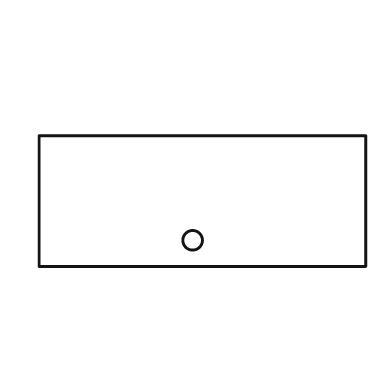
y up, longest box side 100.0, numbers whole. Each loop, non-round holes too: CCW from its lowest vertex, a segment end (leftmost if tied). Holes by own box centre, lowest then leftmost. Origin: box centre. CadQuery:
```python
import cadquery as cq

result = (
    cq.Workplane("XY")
    .moveTo(-50.0, -20.0)
    .lineTo(50.0, -20.0)
    .lineTo(50.0, 20.0)
    .lineTo(-50.0, 20.0)
    .close()
    .moveTo(-3.0, -12.0)
    .circle(3.0)
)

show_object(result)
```